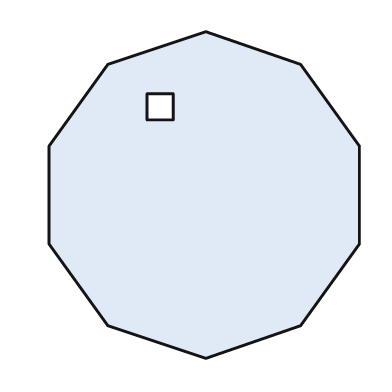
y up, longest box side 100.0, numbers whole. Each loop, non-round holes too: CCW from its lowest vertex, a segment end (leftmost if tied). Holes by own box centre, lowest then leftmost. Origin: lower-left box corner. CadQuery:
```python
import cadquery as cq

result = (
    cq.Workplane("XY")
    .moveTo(48.0, 0.0)
    .lineTo(77.0, 10.0)
    .lineTo(95.0, 35.0)
    .lineTo(95.0, 65.0)
    .lineTo(77.0, 90.0)
    .lineTo(48.0, 100.0)
    .lineTo(18.0, 90.0)
    .lineTo(0.0, 65.0)
    .lineTo(0.0, 35.0)
    .lineTo(18.0, 10.0)
    .close()
    .moveTo(30.0, 73.0)
    .lineTo(38.0, 73.0)
    .lineTo(38.0, 81.0)
    .lineTo(30.0, 81.0)
    .close()
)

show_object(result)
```